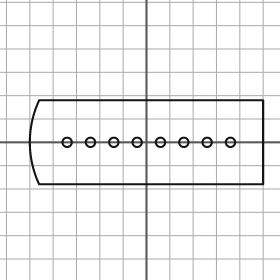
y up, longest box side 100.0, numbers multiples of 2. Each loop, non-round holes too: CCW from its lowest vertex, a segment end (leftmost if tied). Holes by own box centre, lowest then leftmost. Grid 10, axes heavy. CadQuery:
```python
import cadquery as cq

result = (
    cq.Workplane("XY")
    .moveTo(-46.0, -18.0)
    .lineTo(50.0, -18.0)
    .lineTo(50.0, 18.0)
    .lineTo(-46.0, 18.0)
    .threePointArc((-50.0, 0.0), (-46.0, -18.0))
    .close()
    .moveTo(-34.0, 0.0)
    .circle(2.0)
    .moveTo(-24.0, 0.0)
    .circle(2.0)
    .moveTo(-14.0, 0.0)
    .circle(2.0)
    .moveTo(-4.0, 0.0)
    .circle(2.0)
    .moveTo(6.0, 0.0)
    .circle(2.0)
    .moveTo(16.0, 0.0)
    .circle(2.0)
    .moveTo(26.0, 0.0)
    .circle(2.0)
    .moveTo(36.0, 0.0)
    .circle(2.0)
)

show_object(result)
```